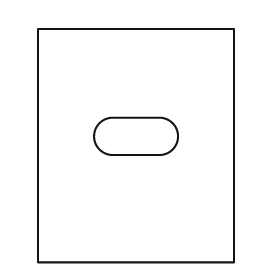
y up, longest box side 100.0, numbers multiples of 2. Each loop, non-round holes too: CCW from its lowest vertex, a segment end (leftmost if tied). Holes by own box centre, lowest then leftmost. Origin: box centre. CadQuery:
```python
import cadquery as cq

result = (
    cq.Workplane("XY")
    .moveTo(-42.0, -50.0)
    .lineTo(42.0, -50.0)
    .lineTo(42.0, 50.0)
    .lineTo(-42.0, 50.0)
    .close()
    .moveTo(-10.0, -4.0)
    .lineTo(10.0, -4.0)
    .threePointArc((18.0, 4.0), (10.0, 12.0))
    .lineTo(-10.0, 12.0)
    .threePointArc((-18.0, 4.0), (-10.0, -4.0))
    .close()
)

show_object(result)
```